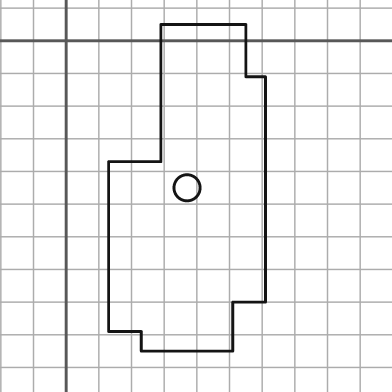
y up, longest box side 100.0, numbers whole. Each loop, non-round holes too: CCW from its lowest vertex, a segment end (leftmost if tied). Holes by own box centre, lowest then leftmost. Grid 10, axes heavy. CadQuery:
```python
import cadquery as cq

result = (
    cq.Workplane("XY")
    .moveTo(23.0, -95.0)
    .lineTo(51.0, -95.0)
    .lineTo(51.0, -80.0)
    .lineTo(61.0, -80.0)
    .lineTo(61.0, -11.0)
    .lineTo(55.0, -11.0)
    .lineTo(55.0, 5.0)
    .lineTo(29.0, 5.0)
    .lineTo(29.0, -37.0)
    .lineTo(13.0, -37.0)
    .lineTo(13.0, -89.0)
    .lineTo(23.0, -89.0)
    .close()
    .moveTo(37.0, -45.0)
    .circle(4.0)
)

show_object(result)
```